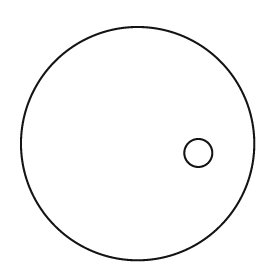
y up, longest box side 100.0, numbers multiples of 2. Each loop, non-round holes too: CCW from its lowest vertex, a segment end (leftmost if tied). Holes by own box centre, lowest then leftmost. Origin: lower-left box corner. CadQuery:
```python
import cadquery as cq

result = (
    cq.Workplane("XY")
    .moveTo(50.0, 50.0)
    .circle(50.0)
    .moveTo(76.0, 46.0)
    .circle(6.0)
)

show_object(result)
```